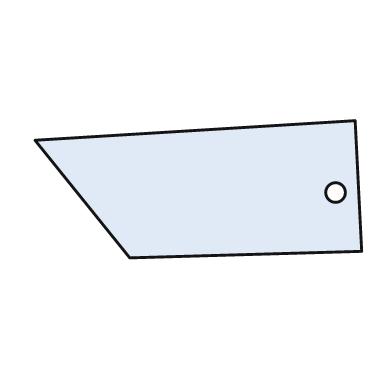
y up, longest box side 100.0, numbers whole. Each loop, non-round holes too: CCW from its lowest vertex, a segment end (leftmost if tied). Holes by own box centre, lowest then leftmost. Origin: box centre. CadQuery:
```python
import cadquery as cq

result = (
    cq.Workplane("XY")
    .moveTo(-21.0, -21.0)
    .lineTo(50.0, -19.0)
    .lineTo(48.0, 21.0)
    .lineTo(-50.0, 15.0)
    .close()
    .moveTo(42.0, -1.0)
    .circle(3.0)
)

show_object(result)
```